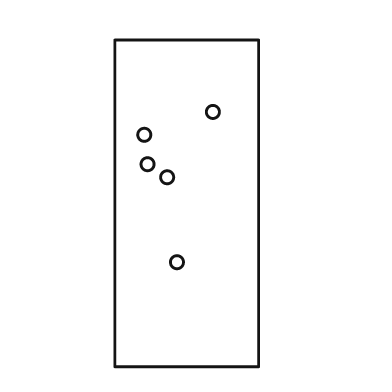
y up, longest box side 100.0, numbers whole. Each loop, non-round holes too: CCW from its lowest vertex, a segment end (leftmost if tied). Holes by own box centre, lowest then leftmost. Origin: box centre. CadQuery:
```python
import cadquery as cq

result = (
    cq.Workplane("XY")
    .moveTo(-22.0, -50.0)
    .lineTo(22.0, -50.0)
    .lineTo(22.0, 50.0)
    .lineTo(-22.0, 50.0)
    .close()
    .moveTo(-3.0, -18.0)
    .circle(2.0)
    .moveTo(-6.0, 8.0)
    .circle(2.0)
    .moveTo(-12.0, 12.0)
    .circle(2.0)
    .moveTo(-13.0, 21.0)
    .circle(2.0)
    .moveTo(8.0, 28.0)
    .circle(2.0)
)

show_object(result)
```